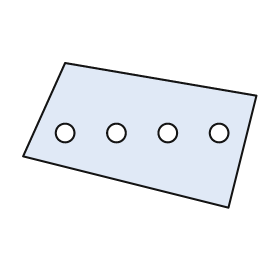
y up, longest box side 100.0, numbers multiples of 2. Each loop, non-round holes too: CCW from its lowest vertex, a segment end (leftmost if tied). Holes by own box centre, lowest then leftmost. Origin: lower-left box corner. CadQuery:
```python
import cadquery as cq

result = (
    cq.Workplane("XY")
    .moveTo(88.0, 0.0)
    .lineTo(100.0, 48.0)
    .lineTo(18.0, 62.0)
    .lineTo(0.0, 22.0)
    .close()
    .moveTo(18.0, 32.0)
    .circle(4.0)
    .moveTo(40.0, 32.0)
    .circle(4.0)
    .moveTo(62.0, 32.0)
    .circle(4.0)
    .moveTo(84.0, 32.0)
    .circle(4.0)
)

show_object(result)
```